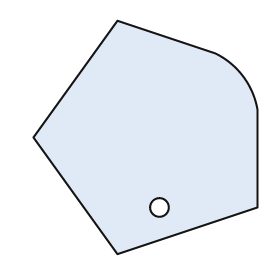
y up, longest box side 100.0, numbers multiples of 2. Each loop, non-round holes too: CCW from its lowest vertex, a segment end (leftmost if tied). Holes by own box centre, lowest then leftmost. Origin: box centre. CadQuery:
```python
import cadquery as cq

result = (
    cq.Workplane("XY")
    .moveTo(-12.0, -50.0)
    .lineTo(48.0, -30.0)
    .lineTo(48.0, 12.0)
    .threePointArc((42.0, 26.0), (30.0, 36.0))
    .lineTo(-12.0, 50.0)
    .lineTo(-48.0, 0.0)
    .close()
    .moveTo(6.0, -30.0)
    .circle(4.0)
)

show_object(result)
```